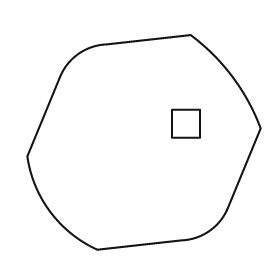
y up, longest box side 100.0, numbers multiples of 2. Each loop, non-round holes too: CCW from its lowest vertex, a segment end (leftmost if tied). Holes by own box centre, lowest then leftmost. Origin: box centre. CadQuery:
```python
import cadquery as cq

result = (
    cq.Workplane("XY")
    .moveTo(-20.0, -46.0)
    .lineTo(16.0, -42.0)
    .threePointArc((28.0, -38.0), (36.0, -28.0))
    .lineTo(50.0, 6.0)
    .threePointArc((38.0, 28.0), (20.0, 46.0))
    .lineTo(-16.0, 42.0)
    .threePointArc((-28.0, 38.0), (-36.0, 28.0))
    .lineTo(-50.0, -6.0)
    .threePointArc((-40.0, -30.0), (-20.0, -46.0))
    .close()
    .moveTo(12.0, 2.0)
    .lineTo(24.0, 2.0)
    .lineTo(24.0, 14.0)
    .lineTo(12.0, 14.0)
    .close()
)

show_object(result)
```